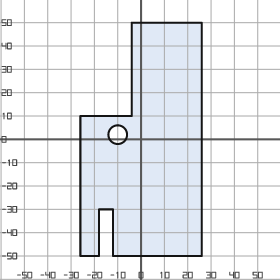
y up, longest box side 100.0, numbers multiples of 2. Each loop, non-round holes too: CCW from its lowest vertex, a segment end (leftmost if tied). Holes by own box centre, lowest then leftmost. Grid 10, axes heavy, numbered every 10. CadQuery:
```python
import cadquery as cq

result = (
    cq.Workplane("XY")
    .moveTo(-26.0, -50.0)
    .lineTo(-18.0, -50.0)
    .lineTo(-18.0, -30.0)
    .lineTo(-12.0, -30.0)
    .lineTo(-12.0, -50.0)
    .lineTo(26.0, -50.0)
    .lineTo(26.0, 50.0)
    .lineTo(-4.0, 50.0)
    .lineTo(-4.0, 10.0)
    .lineTo(-26.0, 10.0)
    .close()
    .moveTo(-10.0, 2.0)
    .circle(4.0)
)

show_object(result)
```